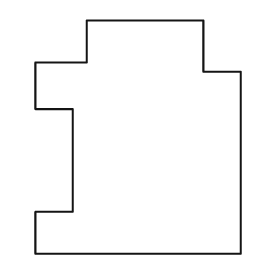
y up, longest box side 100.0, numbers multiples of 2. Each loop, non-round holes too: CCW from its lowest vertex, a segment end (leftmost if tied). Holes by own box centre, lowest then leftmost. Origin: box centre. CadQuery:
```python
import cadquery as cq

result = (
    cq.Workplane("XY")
    .moveTo(-44.0, -50.0)
    .lineTo(44.0, -50.0)
    .lineTo(44.0, 28.0)
    .lineTo(28.0, 28.0)
    .lineTo(28.0, 50.0)
    .lineTo(-22.0, 50.0)
    .lineTo(-22.0, 32.0)
    .lineTo(-44.0, 32.0)
    .lineTo(-44.0, 12.0)
    .lineTo(-28.0, 12.0)
    .lineTo(-28.0, -32.0)
    .lineTo(-44.0, -32.0)
    .close()
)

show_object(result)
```